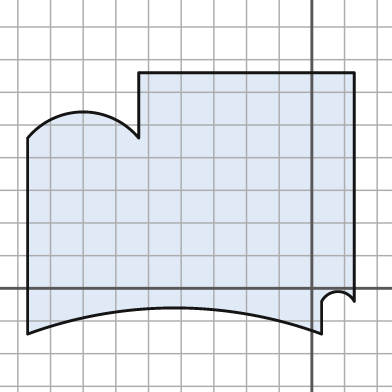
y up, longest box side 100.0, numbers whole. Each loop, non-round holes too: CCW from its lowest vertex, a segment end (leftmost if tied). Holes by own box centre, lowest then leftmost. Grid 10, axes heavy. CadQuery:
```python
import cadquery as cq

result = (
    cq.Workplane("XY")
    .moveTo(-87.0, -14.0)
    .threePointArc((-42.0, -6.0), (3.0, -14.0))
    .lineTo(3.0, -4.0)
    .threePointArc((8.0, -1.0), (13.0, -4.0))
    .lineTo(13.0, 66.0)
    .lineTo(-53.0, 66.0)
    .lineTo(-53.0, 46.0)
    .threePointArc((-70.0, 54.0), (-87.0, 46.0))
    .close()
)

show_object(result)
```